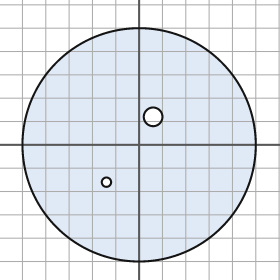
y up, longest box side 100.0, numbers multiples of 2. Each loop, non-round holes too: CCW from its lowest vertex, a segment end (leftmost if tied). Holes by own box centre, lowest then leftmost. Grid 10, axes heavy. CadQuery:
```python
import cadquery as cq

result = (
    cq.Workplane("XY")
    .moveTo(0.0, 0.0)
    .circle(50.0)
    .moveTo(-14.0, -16.0)
    .circle(2.0)
    .moveTo(6.0, 12.0)
    .circle(4.0)
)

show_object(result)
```